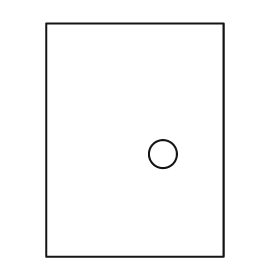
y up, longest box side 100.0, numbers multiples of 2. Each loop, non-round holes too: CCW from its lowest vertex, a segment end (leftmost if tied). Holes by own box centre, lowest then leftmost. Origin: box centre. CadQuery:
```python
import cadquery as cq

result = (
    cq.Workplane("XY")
    .moveTo(-38.0, -50.0)
    .lineTo(38.0, -50.0)
    .lineTo(38.0, 50.0)
    .lineTo(-38.0, 50.0)
    .close()
    .moveTo(12.0, -6.0)
    .circle(6.0)
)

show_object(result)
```